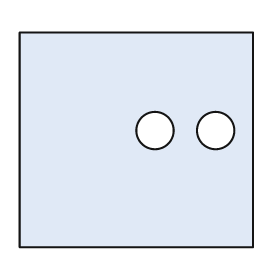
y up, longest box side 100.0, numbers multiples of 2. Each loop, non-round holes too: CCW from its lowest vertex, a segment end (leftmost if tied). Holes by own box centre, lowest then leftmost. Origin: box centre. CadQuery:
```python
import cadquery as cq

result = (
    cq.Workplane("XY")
    .moveTo(-50.0, -46.0)
    .lineTo(50.0, -46.0)
    .lineTo(50.0, 46.0)
    .lineTo(-50.0, 46.0)
    .close()
    .moveTo(8.0, 4.0)
    .circle(8.0)
    .moveTo(34.0, 4.0)
    .circle(8.0)
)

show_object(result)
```